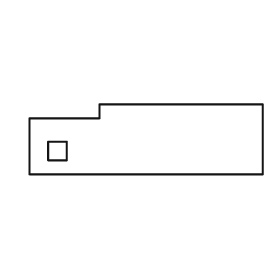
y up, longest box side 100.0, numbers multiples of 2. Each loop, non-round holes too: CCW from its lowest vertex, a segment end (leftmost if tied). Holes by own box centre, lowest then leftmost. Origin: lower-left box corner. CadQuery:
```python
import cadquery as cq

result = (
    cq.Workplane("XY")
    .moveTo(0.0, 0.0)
    .lineTo(100.0, 0.0)
    .lineTo(100.0, 30.0)
    .lineTo(30.0, 30.0)
    .lineTo(30.0, 24.0)
    .lineTo(0.0, 24.0)
    .close()
    .moveTo(8.0, 6.0)
    .lineTo(16.0, 6.0)
    .lineTo(16.0, 14.0)
    .lineTo(8.0, 14.0)
    .close()
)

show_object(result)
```